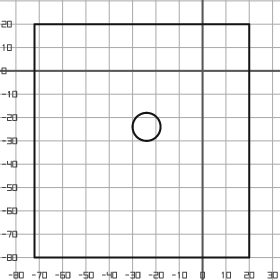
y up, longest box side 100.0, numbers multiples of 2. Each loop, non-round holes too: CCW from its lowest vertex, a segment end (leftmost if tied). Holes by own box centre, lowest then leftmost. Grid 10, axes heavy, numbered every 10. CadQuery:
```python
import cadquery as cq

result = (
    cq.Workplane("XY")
    .moveTo(-72.0, -80.0)
    .lineTo(20.0, -80.0)
    .lineTo(20.0, 20.0)
    .lineTo(-72.0, 20.0)
    .close()
    .moveTo(-24.0, -24.0)
    .circle(6.0)
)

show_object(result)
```